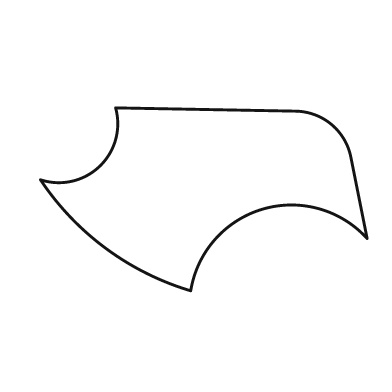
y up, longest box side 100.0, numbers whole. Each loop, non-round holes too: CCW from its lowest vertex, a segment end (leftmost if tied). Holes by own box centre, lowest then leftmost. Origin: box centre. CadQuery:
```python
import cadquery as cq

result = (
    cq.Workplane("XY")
    .moveTo(-4.0, -28.0)
    .threePointArc((18.0, -3.0), (50.0, -12.0))
    .lineTo(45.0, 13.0)
    .threePointArc((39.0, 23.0), (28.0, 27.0))
    .lineTo(-27.0, 28.0)
    .threePointArc((-32.0, 10.0), (-50.0, 6.0))
    .threePointArc((-30.0, -15.0), (-4.0, -28.0))
    .close()
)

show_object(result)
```